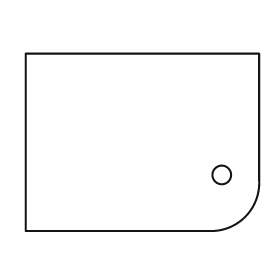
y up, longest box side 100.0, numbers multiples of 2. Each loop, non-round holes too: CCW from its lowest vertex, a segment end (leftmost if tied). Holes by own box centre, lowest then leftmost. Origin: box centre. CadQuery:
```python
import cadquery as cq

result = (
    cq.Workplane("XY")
    .moveTo(-50.0, -38.0)
    .lineTo(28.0, -38.0)
    .threePointArc((44.0, -32.0), (50.0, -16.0))
    .lineTo(50.0, 38.0)
    .lineTo(-50.0, 38.0)
    .close()
    .moveTo(34.0, -14.0)
    .circle(4.0)
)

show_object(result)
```